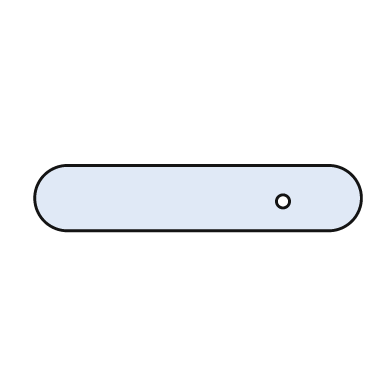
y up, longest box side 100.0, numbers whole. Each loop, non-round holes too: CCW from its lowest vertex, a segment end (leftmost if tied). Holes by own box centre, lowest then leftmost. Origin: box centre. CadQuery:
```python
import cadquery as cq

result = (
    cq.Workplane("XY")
    .moveTo(-40.0, -10.0)
    .lineTo(40.0, -10.0)
    .threePointArc((50.0, 0.0), (40.0, 10.0))
    .lineTo(-40.0, 10.0)
    .threePointArc((-50.0, 0.0), (-40.0, -10.0))
    .close()
    .moveTo(26.0, -1.0)
    .circle(2.0)
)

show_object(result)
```